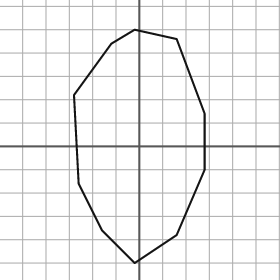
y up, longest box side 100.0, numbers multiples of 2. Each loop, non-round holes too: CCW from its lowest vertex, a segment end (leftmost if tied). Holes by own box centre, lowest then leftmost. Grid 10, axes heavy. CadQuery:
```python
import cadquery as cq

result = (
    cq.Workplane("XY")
    .moveTo(-2.0, -50.0)
    .lineTo(16.0, -38.0)
    .lineTo(28.0, -10.0)
    .lineTo(28.0, 14.0)
    .lineTo(16.0, 46.0)
    .lineTo(-2.0, 50.0)
    .lineTo(-12.0, 44.0)
    .lineTo(-28.0, 22.0)
    .lineTo(-26.0, -16.0)
    .lineTo(-16.0, -36.0)
    .close()
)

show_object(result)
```